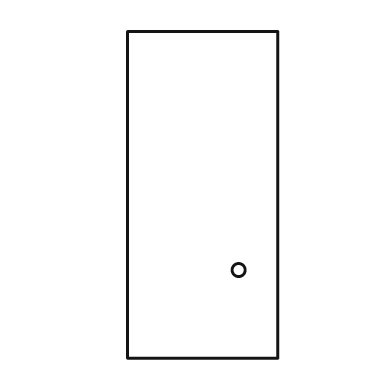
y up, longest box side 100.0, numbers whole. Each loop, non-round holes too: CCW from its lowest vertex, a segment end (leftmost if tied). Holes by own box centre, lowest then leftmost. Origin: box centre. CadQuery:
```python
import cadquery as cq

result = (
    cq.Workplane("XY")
    .moveTo(-23.0, -50.0)
    .lineTo(23.0, -50.0)
    .lineTo(23.0, 50.0)
    .lineTo(-23.0, 50.0)
    .close()
    .moveTo(11.0, -23.0)
    .circle(2.0)
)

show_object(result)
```